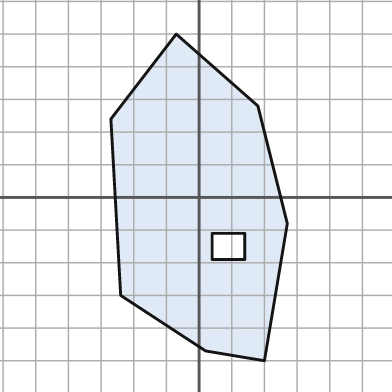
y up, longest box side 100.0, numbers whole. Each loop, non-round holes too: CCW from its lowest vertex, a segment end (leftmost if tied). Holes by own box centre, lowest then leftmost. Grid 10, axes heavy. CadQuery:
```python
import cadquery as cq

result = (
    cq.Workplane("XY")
    .moveTo(20.0, -50.0)
    .lineTo(27.0, -8.0)
    .lineTo(18.0, 28.0)
    .lineTo(-7.0, 50.0)
    .lineTo(-27.0, 24.0)
    .lineTo(-24.0, -30.0)
    .lineTo(2.0, -47.0)
    .close()
    .moveTo(4.0, -19.0)
    .lineTo(14.0, -19.0)
    .lineTo(14.0, -11.0)
    .lineTo(4.0, -11.0)
    .close()
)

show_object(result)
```